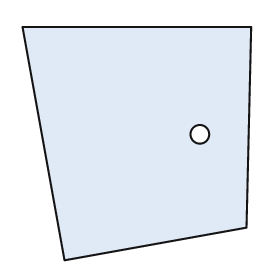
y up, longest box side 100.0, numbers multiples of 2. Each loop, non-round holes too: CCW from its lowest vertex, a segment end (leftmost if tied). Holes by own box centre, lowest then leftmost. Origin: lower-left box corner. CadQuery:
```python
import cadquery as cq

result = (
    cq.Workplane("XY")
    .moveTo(18.0, 0.0)
    .lineTo(96.0, 14.0)
    .lineTo(98.0, 100.0)
    .lineTo(0.0, 100.0)
    .close()
    .moveTo(76.0, 54.0)
    .circle(4.0)
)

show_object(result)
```